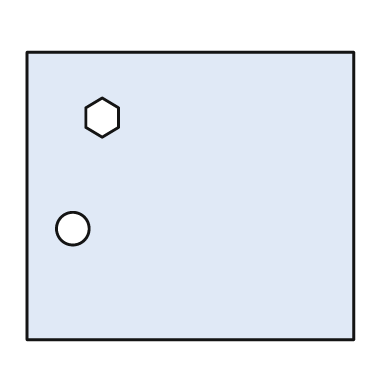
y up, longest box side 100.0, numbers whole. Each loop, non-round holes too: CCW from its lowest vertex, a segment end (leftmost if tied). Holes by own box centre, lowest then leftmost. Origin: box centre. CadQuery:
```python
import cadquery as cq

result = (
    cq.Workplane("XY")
    .moveTo(-50.0, -44.0)
    .lineTo(50.0, -44.0)
    .lineTo(50.0, 44.0)
    .lineTo(-50.0, 44.0)
    .close()
    .moveTo(-36.0, -10.0)
    .circle(5.0)
    .moveTo(-27.0, 18.0)
    .lineTo(-22.0, 21.0)
    .lineTo(-22.0, 27.0)
    .lineTo(-27.0, 30.0)
    .lineTo(-32.0, 27.0)
    .lineTo(-32.0, 21.0)
    .close()
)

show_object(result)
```